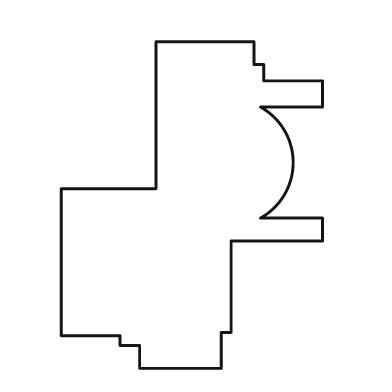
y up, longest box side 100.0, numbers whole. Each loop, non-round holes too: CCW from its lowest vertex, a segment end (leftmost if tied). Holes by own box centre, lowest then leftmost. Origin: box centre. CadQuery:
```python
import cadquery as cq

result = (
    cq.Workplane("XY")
    .moveTo(-16.0, -50.0)
    .lineTo(9.0, -50.0)
    .lineTo(9.0, -39.0)
    .lineTo(12.0, -39.0)
    .lineTo(12.0, -11.0)
    .lineTo(40.0, -11.0)
    .lineTo(40.0, -4.0)
    .lineTo(21.0, -4.0)
    .threePointArc((31.0, 13.0), (21.0, 30.0))
    .lineTo(40.0, 30.0)
    .lineTo(40.0, 38.0)
    .lineTo(22.0, 38.0)
    .lineTo(22.0, 43.0)
    .lineTo(19.0, 43.0)
    .lineTo(19.0, 50.0)
    .lineTo(-11.0, 50.0)
    .lineTo(-11.0, 5.0)
    .lineTo(-40.0, 5.0)
    .lineTo(-40.0, -40.0)
    .lineTo(-22.0, -40.0)
    .lineTo(-22.0, -43.0)
    .lineTo(-16.0, -43.0)
    .close()
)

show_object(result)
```